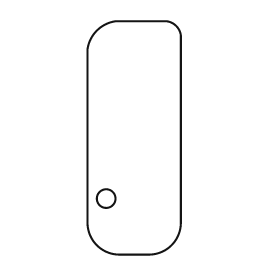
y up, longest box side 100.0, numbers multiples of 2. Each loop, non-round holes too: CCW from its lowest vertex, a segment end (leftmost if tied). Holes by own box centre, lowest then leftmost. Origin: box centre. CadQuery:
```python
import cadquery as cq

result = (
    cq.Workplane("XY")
    .moveTo(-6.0, -50.0)
    .lineTo(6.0, -50.0)
    .threePointArc((16.0, -46.0), (20.0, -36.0))
    .lineTo(20.0, 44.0)
    .threePointArc((18.0, 48.0), (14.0, 50.0))
    .lineTo(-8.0, 50.0)
    .threePointArc((-16.0, 46.0), (-20.0, 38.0))
    .lineTo(-20.0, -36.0)
    .threePointArc((-16.0, -46.0), (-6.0, -50.0))
    .close()
    .moveTo(-12.0, -26.0)
    .circle(4.0)
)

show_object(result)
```